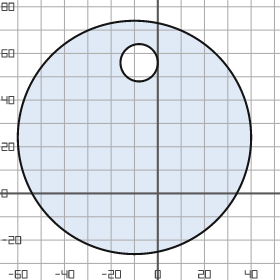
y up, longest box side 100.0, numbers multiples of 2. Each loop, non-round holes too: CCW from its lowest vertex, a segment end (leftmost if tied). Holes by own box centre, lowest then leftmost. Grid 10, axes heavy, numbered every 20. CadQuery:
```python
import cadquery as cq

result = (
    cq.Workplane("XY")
    .moveTo(-10.0, 24.0)
    .circle(50.0)
    .moveTo(-8.0, 56.0)
    .circle(8.0)
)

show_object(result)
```